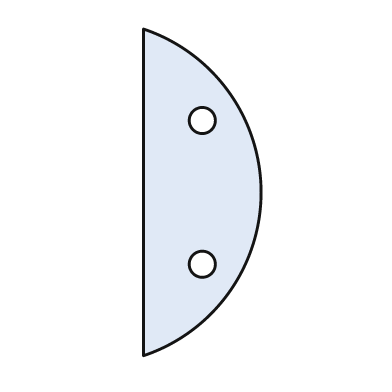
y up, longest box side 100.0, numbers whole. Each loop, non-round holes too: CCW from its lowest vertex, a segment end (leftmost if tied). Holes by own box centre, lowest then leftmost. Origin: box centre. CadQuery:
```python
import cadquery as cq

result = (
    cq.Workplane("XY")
    .moveTo(-18.0, -50.0)
    .threePointArc((18.0, 0.0), (-18.0, 50.0))
    .close()
    .moveTo(0.0, -22.0)
    .circle(4.0)
    .moveTo(0.0, 22.0)
    .circle(4.0)
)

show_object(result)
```